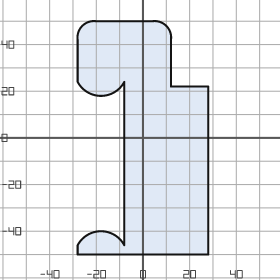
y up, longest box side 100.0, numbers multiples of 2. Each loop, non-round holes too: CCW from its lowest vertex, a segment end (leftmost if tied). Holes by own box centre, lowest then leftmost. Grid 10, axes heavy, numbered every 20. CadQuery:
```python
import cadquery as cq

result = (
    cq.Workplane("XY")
    .moveTo(-28.0, -50.0)
    .lineTo(28.0, -50.0)
    .lineTo(28.0, 22.0)
    .lineTo(12.0, 22.0)
    .lineTo(12.0, 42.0)
    .threePointArc((10.0, 48.0), (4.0, 50.0))
    .lineTo(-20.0, 50.0)
    .threePointArc((-26.0, 48.0), (-28.0, 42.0))
    .lineTo(-28.0, 24.0)
    .threePointArc((-18.0, 18.0), (-8.0, 24.0))
    .lineTo(-8.0, -46.0)
    .threePointArc((-18.0, -40.0), (-28.0, -46.0))
    .close()
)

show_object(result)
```